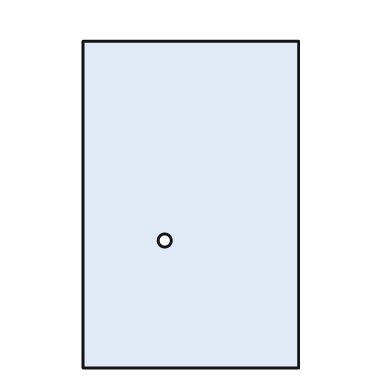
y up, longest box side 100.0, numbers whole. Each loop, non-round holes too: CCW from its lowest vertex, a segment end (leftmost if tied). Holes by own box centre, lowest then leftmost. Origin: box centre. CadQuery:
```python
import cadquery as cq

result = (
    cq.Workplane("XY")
    .moveTo(-33.0, -50.0)
    .lineTo(33.0, -50.0)
    .lineTo(33.0, 50.0)
    .lineTo(-33.0, 50.0)
    .close()
    .moveTo(-8.0, -11.0)
    .circle(2.0)
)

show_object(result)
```